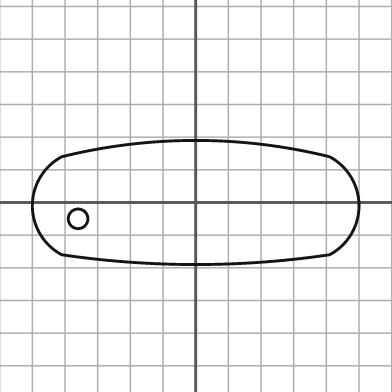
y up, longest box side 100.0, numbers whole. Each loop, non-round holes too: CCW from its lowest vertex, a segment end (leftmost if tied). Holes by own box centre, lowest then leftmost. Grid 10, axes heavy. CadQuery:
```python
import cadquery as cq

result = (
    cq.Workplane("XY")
    .moveTo(-41.0, -16.0)
    .threePointArc((0.0, -19.0), (41.0, -16.0))
    .threePointArc((50.0, -1.0), (41.0, 14.0))
    .threePointArc((0.0, 19.0), (-41.0, 14.0))
    .threePointArc((-50.0, -1.0), (-41.0, -16.0))
    .close()
    .moveTo(-36.0, -5.0)
    .circle(3.0)
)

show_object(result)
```